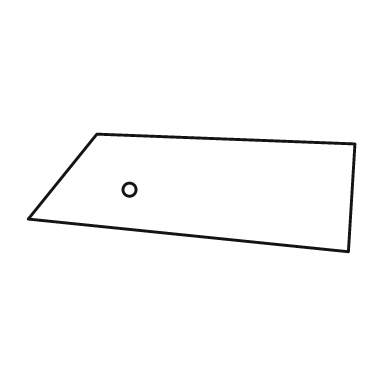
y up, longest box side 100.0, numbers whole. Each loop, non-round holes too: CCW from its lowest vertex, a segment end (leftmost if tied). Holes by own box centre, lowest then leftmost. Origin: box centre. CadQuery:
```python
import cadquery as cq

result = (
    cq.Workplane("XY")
    .moveTo(48.0, -18.0)
    .lineTo(50.0, 15.0)
    .lineTo(-29.0, 18.0)
    .lineTo(-50.0, -8.0)
    .close()
    .moveTo(-19.0, 1.0)
    .circle(2.0)
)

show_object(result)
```